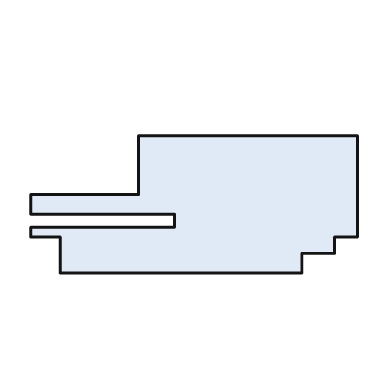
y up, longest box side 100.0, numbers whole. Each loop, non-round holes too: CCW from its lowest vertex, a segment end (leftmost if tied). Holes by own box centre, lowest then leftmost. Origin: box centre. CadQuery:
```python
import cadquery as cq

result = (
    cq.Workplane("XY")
    .moveTo(-41.0, -21.0)
    .lineTo(33.0, -21.0)
    .lineTo(33.0, -15.0)
    .lineTo(43.0, -15.0)
    .lineTo(43.0, -10.0)
    .lineTo(50.0, -10.0)
    .lineTo(50.0, 21.0)
    .lineTo(-17.0, 21.0)
    .lineTo(-17.0, 3.0)
    .lineTo(-50.0, 3.0)
    .lineTo(-50.0, -3.0)
    .lineTo(-6.0, -3.0)
    .lineTo(-6.0, -7.0)
    .lineTo(-50.0, -7.0)
    .lineTo(-50.0, -10.0)
    .lineTo(-41.0, -10.0)
    .close()
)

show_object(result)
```